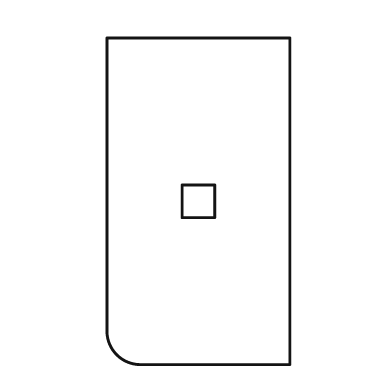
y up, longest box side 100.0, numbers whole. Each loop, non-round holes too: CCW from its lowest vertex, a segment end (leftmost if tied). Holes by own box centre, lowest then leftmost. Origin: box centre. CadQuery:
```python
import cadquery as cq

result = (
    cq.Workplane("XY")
    .moveTo(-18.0, -50.0)
    .lineTo(28.0, -50.0)
    .lineTo(28.0, 50.0)
    .lineTo(-28.0, 50.0)
    .lineTo(-28.0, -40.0)
    .threePointArc((-25.0, -47.0), (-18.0, -50.0))
    .close()
    .moveTo(-5.0, -5.0)
    .lineTo(5.0, -5.0)
    .lineTo(5.0, 5.0)
    .lineTo(-5.0, 5.0)
    .close()
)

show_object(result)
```